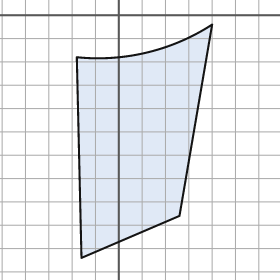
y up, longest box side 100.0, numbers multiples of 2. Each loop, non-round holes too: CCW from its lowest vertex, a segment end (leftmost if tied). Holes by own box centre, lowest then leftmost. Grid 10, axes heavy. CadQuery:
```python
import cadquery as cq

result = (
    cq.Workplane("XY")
    .moveTo(-16.0, -104.0)
    .lineTo(26.0, -86.0)
    .lineTo(40.0, -4.0)
    .threePointArc((12.0, -16.0), (-18.0, -18.0))
    .close()
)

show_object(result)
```